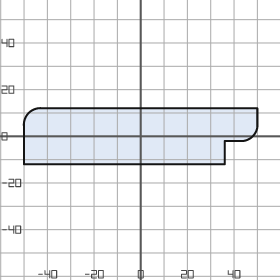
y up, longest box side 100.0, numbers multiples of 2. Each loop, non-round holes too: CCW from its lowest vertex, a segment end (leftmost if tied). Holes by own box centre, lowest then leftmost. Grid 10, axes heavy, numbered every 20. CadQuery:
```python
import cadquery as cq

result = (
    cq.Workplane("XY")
    .moveTo(-50.0, -12.0)
    .lineTo(36.0, -12.0)
    .lineTo(36.0, -2.0)
    .lineTo(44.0, -2.0)
    .threePointArc((48.0, 0.0), (50.0, 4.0))
    .lineTo(50.0, 12.0)
    .lineTo(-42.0, 12.0)
    .threePointArc((-48.0, 10.0), (-50.0, 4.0))
    .close()
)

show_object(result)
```